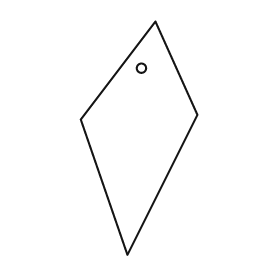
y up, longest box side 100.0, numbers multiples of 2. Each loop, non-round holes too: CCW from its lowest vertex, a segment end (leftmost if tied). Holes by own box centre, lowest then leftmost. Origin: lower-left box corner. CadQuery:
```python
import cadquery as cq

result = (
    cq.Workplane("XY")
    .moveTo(20.0, 0.0)
    .lineTo(50.0, 60.0)
    .lineTo(32.0, 100.0)
    .lineTo(0.0, 58.0)
    .close()
    .moveTo(26.0, 80.0)
    .circle(2.0)
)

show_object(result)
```